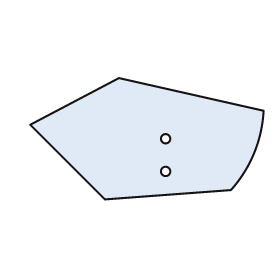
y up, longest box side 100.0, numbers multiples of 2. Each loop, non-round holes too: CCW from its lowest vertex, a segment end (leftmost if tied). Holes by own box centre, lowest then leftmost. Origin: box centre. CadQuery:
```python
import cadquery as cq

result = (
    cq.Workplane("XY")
    .moveTo(-18.0, -26.0)
    .lineTo(36.0, -22.0)
    .threePointArc((46.0, -6.0), (50.0, 12.0))
    .lineTo(-12.0, 26.0)
    .lineTo(-50.0, 6.0)
    .close()
    .moveTo(8.0, -14.0)
    .circle(2.0)
    .moveTo(8.0, 0.0)
    .circle(2.0)
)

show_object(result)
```